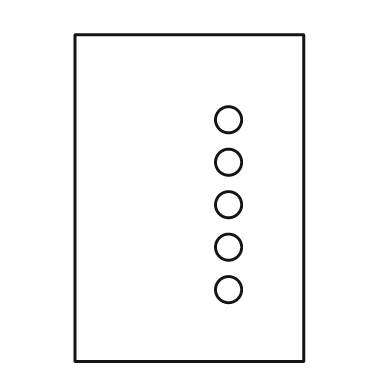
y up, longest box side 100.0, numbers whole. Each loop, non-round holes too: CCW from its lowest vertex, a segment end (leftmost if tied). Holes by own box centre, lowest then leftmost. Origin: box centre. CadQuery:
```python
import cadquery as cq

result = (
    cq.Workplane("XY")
    .moveTo(-35.0, -50.0)
    .lineTo(35.0, -50.0)
    .lineTo(35.0, 50.0)
    .lineTo(-35.0, 50.0)
    .close()
    .moveTo(12.0, -28.0)
    .circle(4.0)
    .moveTo(12.0, -15.0)
    .circle(4.0)
    .moveTo(12.0, -2.0)
    .circle(4.0)
    .moveTo(12.0, 11.0)
    .circle(4.0)
    .moveTo(12.0, 24.0)
    .circle(4.0)
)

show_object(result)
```